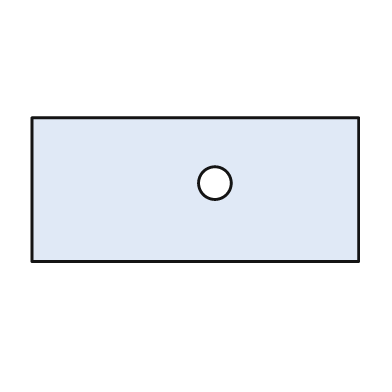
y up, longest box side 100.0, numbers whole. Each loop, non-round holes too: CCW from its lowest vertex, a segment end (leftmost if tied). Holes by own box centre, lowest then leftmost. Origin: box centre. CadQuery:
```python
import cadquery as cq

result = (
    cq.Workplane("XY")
    .moveTo(-50.0, -22.0)
    .lineTo(50.0, -22.0)
    .lineTo(50.0, 22.0)
    .lineTo(-50.0, 22.0)
    .close()
    .moveTo(6.0, 2.0)
    .circle(5.0)
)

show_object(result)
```